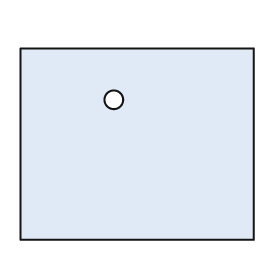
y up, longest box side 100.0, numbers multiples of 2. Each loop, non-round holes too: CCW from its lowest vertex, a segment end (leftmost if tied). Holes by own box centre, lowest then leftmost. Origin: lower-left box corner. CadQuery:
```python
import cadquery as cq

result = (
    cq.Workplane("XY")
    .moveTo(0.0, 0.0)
    .lineTo(100.0, 0.0)
    .lineTo(100.0, 82.0)
    .lineTo(0.0, 82.0)
    .close()
    .moveTo(40.0, 60.0)
    .circle(4.0)
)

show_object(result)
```